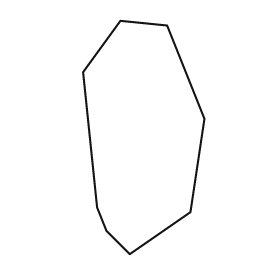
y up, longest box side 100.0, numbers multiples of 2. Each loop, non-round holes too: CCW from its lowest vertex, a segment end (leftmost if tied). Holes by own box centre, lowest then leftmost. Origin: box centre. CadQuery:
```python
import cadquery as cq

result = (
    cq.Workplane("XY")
    .moveTo(-6.0, -50.0)
    .lineTo(20.0, -32.0)
    .lineTo(26.0, 8.0)
    .lineTo(10.0, 48.0)
    .lineTo(-10.0, 50.0)
    .lineTo(-26.0, 28.0)
    .lineTo(-20.0, -30.0)
    .lineTo(-16.0, -40.0)
    .close()
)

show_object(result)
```